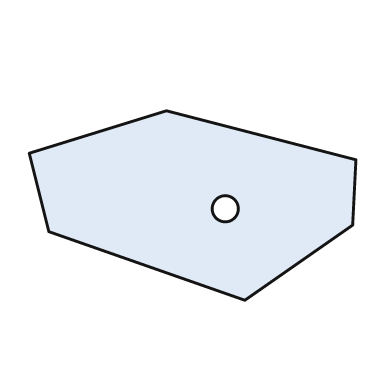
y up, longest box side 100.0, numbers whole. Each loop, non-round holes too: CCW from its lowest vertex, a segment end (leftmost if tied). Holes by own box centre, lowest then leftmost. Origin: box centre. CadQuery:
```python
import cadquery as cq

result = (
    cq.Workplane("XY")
    .moveTo(16.0, -29.0)
    .lineTo(49.0, -6.0)
    .lineTo(50.0, 14.0)
    .lineTo(-8.0, 29.0)
    .lineTo(-50.0, 16.0)
    .lineTo(-44.0, -8.0)
    .close()
    .moveTo(10.0, -1.0)
    .circle(4.0)
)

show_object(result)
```